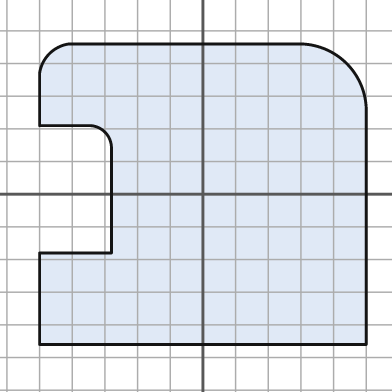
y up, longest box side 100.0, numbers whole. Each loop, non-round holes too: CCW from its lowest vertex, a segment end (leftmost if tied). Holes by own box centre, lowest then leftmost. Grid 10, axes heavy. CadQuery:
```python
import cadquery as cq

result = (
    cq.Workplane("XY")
    .moveTo(-50.0, -46.0)
    .lineTo(50.0, -46.0)
    .lineTo(50.0, 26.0)
    .threePointArc((44.0, 40.0), (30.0, 46.0))
    .lineTo(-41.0, 46.0)
    .threePointArc((-47.0, 43.0), (-50.0, 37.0))
    .lineTo(-50.0, 21.0)
    .lineTo(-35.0, 21.0)
    .threePointArc((-30.0, 19.0), (-28.0, 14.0))
    .lineTo(-28.0, -18.0)
    .lineTo(-50.0, -18.0)
    .close()
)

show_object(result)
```